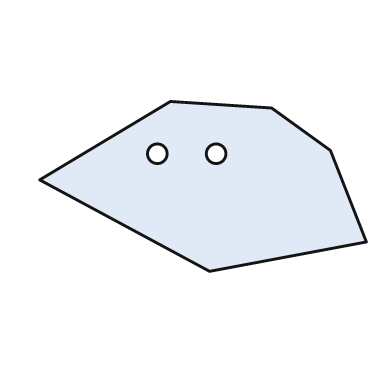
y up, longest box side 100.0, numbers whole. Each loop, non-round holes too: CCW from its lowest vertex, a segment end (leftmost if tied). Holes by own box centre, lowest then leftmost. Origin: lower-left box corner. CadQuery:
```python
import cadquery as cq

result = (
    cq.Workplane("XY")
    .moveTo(52.0, 0.0)
    .lineTo(100.0, 9.0)
    .lineTo(89.0, 37.0)
    .lineTo(71.0, 50.0)
    .lineTo(40.0, 52.0)
    .lineTo(0.0, 28.0)
    .close()
    .moveTo(36.0, 36.0)
    .circle(3.0)
    .moveTo(54.0, 36.0)
    .circle(3.0)
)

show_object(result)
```